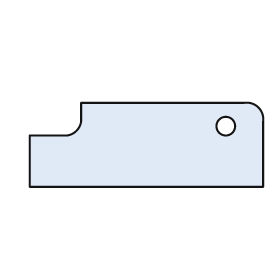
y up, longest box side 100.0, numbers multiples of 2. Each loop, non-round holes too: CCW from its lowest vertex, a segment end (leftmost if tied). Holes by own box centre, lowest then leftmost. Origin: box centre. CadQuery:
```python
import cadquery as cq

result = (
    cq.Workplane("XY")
    .moveTo(-50.0, -18.0)
    .lineTo(50.0, -18.0)
    .lineTo(50.0, 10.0)
    .threePointArc((48.0, 16.0), (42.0, 18.0))
    .lineTo(-28.0, 18.0)
    .lineTo(-28.0, 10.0)
    .threePointArc((-30.0, 6.0), (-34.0, 4.0))
    .lineTo(-50.0, 4.0)
    .close()
    .moveTo(34.0, 8.0)
    .circle(4.0)
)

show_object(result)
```